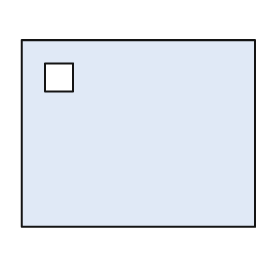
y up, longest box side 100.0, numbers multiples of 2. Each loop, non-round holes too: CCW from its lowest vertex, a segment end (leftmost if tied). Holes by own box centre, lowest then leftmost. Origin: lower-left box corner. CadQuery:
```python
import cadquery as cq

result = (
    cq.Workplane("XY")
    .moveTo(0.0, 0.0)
    .lineTo(100.0, 0.0)
    .lineTo(100.0, 80.0)
    .lineTo(0.0, 80.0)
    .close()
    .moveTo(10.0, 58.0)
    .lineTo(22.0, 58.0)
    .lineTo(22.0, 70.0)
    .lineTo(10.0, 70.0)
    .close()
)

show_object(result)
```